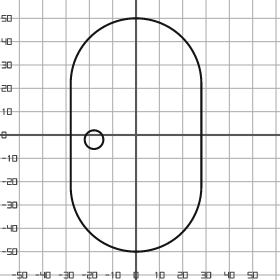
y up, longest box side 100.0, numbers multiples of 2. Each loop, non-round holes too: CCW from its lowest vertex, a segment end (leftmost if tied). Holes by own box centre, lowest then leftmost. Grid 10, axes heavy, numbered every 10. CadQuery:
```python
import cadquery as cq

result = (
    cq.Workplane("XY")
    .moveTo(-28.0, -22.0)
    .threePointArc((0.0, -50.0), (28.0, -22.0))
    .lineTo(28.0, 22.0)
    .threePointArc((0.0, 50.0), (-28.0, 22.0))
    .close()
    .moveTo(-18.0, -2.0)
    .circle(4.0)
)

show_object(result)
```